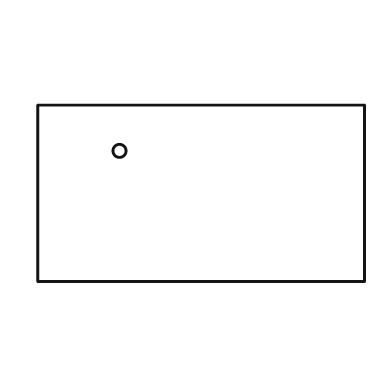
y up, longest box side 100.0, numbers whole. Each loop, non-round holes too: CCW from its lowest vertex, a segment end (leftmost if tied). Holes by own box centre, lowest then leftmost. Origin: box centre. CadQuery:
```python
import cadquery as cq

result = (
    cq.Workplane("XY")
    .moveTo(-50.0, -27.0)
    .lineTo(50.0, -27.0)
    .lineTo(50.0, 27.0)
    .lineTo(-50.0, 27.0)
    .close()
    .moveTo(-25.0, 13.0)
    .circle(2.0)
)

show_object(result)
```